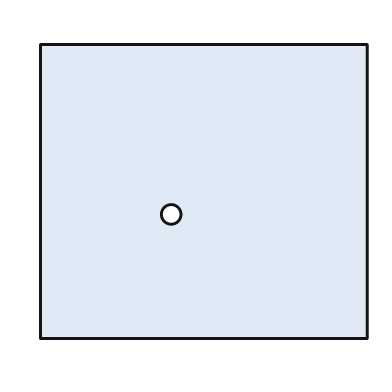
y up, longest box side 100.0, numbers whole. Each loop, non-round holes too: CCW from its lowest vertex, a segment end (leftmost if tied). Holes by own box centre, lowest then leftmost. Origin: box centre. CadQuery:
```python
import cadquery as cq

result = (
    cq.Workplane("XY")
    .moveTo(-50.0, -45.0)
    .lineTo(50.0, -45.0)
    .lineTo(50.0, 45.0)
    .lineTo(-50.0, 45.0)
    .close()
    .moveTo(-10.0, -7.0)
    .circle(3.0)
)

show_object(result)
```